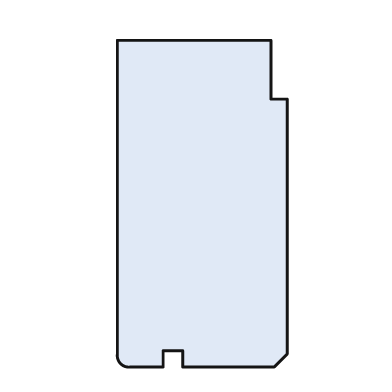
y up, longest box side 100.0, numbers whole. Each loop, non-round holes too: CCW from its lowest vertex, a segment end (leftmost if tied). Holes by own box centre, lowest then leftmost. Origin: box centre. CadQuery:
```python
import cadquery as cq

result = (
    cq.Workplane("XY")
    .moveTo(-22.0, -50.0)
    .lineTo(-12.0, -50.0)
    .lineTo(-12.0, -45.0)
    .lineTo(-6.0, -45.0)
    .lineTo(-6.0, -50.0)
    .lineTo(22.0, -50.0)
    .lineTo(26.0, -46.0)
    .lineTo(26.0, 32.0)
    .lineTo(21.0, 32.0)
    .lineTo(21.0, 50.0)
    .lineTo(-26.0, 50.0)
    .lineTo(-26.0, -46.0)
    .threePointArc((-25.0, -49.0), (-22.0, -50.0))
    .close()
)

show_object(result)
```